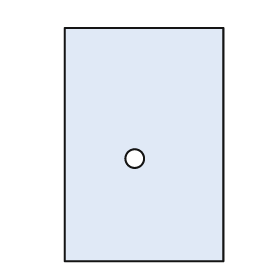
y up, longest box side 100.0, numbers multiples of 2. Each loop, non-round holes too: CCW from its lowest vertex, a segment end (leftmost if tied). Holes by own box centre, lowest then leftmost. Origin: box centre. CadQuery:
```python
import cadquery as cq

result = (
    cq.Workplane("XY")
    .moveTo(-34.0, -50.0)
    .lineTo(34.0, -50.0)
    .lineTo(34.0, 50.0)
    .lineTo(-34.0, 50.0)
    .close()
    .moveTo(-4.0, -6.0)
    .circle(4.0)
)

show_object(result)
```